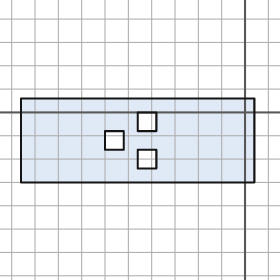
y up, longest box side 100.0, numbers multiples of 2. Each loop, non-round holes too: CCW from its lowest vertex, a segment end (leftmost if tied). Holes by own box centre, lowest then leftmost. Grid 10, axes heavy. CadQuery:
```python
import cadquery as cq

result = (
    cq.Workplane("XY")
    .moveTo(-96.0, -30.0)
    .lineTo(4.0, -30.0)
    .lineTo(4.0, 6.0)
    .lineTo(-96.0, 6.0)
    .close()
    .moveTo(-46.0, -24.0)
    .lineTo(-38.0, -24.0)
    .lineTo(-38.0, -16.0)
    .lineTo(-46.0, -16.0)
    .close()
    .moveTo(-60.0, -16.0)
    .lineTo(-52.0, -16.0)
    .lineTo(-52.0, -8.0)
    .lineTo(-60.0, -8.0)
    .close()
    .moveTo(-46.0, -8.0)
    .lineTo(-38.0, -8.0)
    .lineTo(-38.0, 0.0)
    .lineTo(-46.0, 0.0)
    .close()
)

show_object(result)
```